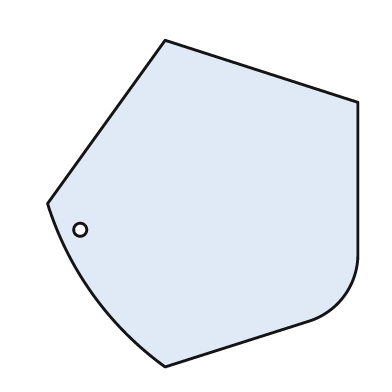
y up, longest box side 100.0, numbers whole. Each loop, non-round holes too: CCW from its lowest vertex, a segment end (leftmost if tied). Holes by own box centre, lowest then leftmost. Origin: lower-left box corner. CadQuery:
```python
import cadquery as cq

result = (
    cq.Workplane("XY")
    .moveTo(36.0, 0.0)
    .lineTo(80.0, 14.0)
    .threePointArc((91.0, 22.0), (95.0, 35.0))
    .lineTo(95.0, 81.0)
    .lineTo(36.0, 100.0)
    .lineTo(0.0, 50.0)
    .threePointArc((14.0, 22.0), (36.0, 0.0))
    .close()
    .moveTo(10.0, 42.0)
    .circle(2.0)
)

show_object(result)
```